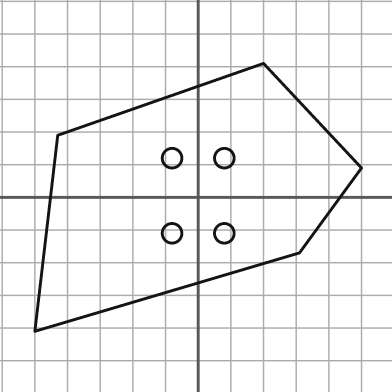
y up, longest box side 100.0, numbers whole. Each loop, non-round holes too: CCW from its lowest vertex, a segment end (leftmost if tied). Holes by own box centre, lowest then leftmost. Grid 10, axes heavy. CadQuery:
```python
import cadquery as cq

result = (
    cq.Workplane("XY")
    .moveTo(-50.0, -41.0)
    .lineTo(31.0, -17.0)
    .lineTo(50.0, 9.0)
    .lineTo(20.0, 41.0)
    .lineTo(-43.0, 19.0)
    .close()
    .moveTo(-8.0, -11.0)
    .circle(3.0)
    .moveTo(8.0, -11.0)
    .circle(3.0)
    .moveTo(-8.0, 12.0)
    .circle(3.0)
    .moveTo(8.0, 12.0)
    .circle(3.0)
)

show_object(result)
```